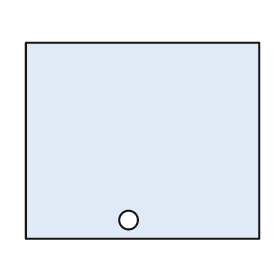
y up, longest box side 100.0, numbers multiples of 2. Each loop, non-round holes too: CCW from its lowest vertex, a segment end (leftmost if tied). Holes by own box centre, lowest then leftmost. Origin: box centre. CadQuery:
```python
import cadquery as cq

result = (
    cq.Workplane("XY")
    .moveTo(-50.0, -42.0)
    .lineTo(50.0, -42.0)
    .lineTo(50.0, 42.0)
    .lineTo(-50.0, 42.0)
    .close()
    .moveTo(-6.0, -34.0)
    .circle(4.0)
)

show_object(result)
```